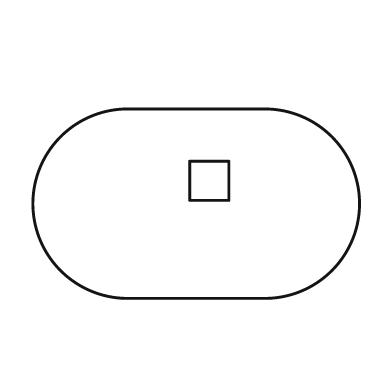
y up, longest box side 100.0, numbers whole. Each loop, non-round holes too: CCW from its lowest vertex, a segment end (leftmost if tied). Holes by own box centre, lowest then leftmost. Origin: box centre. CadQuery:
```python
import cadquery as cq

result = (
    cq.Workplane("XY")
    .moveTo(-21.0, -29.0)
    .lineTo(21.0, -29.0)
    .threePointArc((50.0, 0.0), (21.0, 29.0))
    .lineTo(-21.0, 29.0)
    .threePointArc((-50.0, 0.0), (-21.0, -29.0))
    .close()
    .moveTo(-2.0, 1.0)
    .lineTo(10.0, 1.0)
    .lineTo(10.0, 13.0)
    .lineTo(-2.0, 13.0)
    .close()
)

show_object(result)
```